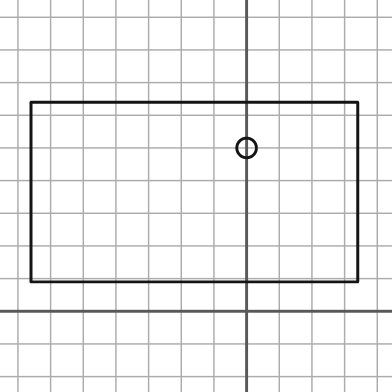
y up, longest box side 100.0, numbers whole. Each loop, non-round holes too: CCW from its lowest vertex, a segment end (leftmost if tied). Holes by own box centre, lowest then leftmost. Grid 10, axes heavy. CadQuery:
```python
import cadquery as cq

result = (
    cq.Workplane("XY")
    .moveTo(-66.0, 9.0)
    .lineTo(34.0, 9.0)
    .lineTo(34.0, 64.0)
    .lineTo(-66.0, 64.0)
    .close()
    .moveTo(0.0, 50.0)
    .circle(3.0)
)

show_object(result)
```